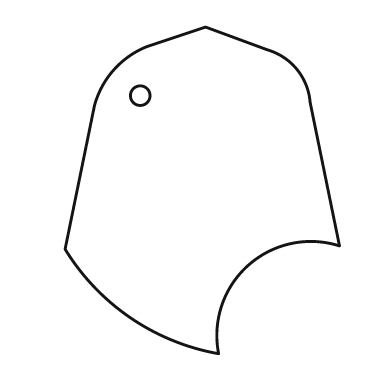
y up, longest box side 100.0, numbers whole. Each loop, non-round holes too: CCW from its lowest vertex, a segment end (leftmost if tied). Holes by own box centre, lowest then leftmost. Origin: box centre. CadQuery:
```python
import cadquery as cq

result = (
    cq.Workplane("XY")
    .moveTo(5.0, -50.0)
    .threePointArc((14.0, -23.0), (42.0, -17.0))
    .lineTo(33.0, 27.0)
    .threePointArc((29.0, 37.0), (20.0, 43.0))
    .lineTo(1.0, 50.0)
    .lineTo(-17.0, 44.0)
    .threePointArc((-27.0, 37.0), (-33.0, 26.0))
    .lineTo(-42.0, -18.0)
    .threePointArc((-22.0, -39.0), (5.0, -50.0))
    .close()
    .moveTo(-19.0, 29.0)
    .circle(3.0)
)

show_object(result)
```